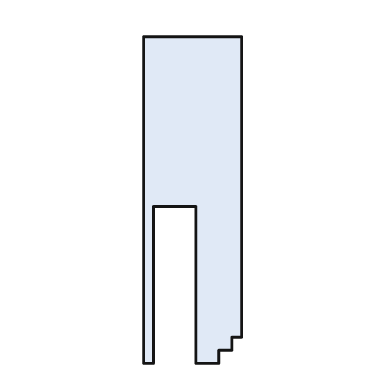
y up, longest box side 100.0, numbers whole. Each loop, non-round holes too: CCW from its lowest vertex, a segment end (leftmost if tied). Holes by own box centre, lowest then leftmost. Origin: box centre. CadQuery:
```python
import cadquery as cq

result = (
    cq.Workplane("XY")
    .moveTo(-15.0, -50.0)
    .lineTo(-12.0, -50.0)
    .lineTo(-12.0, -2.0)
    .lineTo(1.0, -2.0)
    .lineTo(1.0, -50.0)
    .lineTo(8.0, -50.0)
    .lineTo(8.0, -46.0)
    .lineTo(12.0, -46.0)
    .lineTo(12.0, -42.0)
    .lineTo(15.0, -42.0)
    .lineTo(15.0, 50.0)
    .lineTo(-15.0, 50.0)
    .close()
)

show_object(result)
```